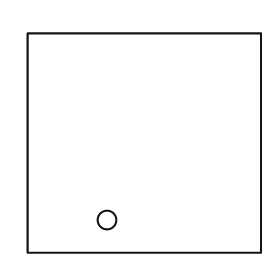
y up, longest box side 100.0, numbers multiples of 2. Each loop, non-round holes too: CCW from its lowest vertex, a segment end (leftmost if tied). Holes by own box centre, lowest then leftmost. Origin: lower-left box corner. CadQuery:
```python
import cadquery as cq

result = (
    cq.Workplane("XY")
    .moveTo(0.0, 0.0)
    .lineTo(100.0, 0.0)
    .lineTo(100.0, 94.0)
    .lineTo(0.0, 94.0)
    .close()
    .moveTo(34.0, 14.0)
    .circle(4.0)
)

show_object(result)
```